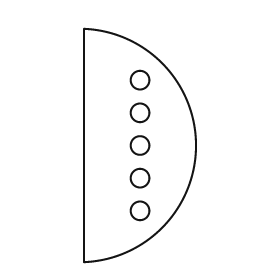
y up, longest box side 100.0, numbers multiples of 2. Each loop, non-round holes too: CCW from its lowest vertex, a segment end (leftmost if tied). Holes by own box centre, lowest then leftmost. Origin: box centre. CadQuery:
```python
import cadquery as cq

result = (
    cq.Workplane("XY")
    .moveTo(-24.0, -50.0)
    .threePointArc((24.0, 0.0), (-24.0, 50.0))
    .close()
    .moveTo(0.0, -28.0)
    .circle(4.0)
    .moveTo(0.0, -14.0)
    .circle(4.0)
    .moveTo(0.0, 0.0)
    .circle(4.0)
    .moveTo(0.0, 14.0)
    .circle(4.0)
    .moveTo(0.0, 28.0)
    .circle(4.0)
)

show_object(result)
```